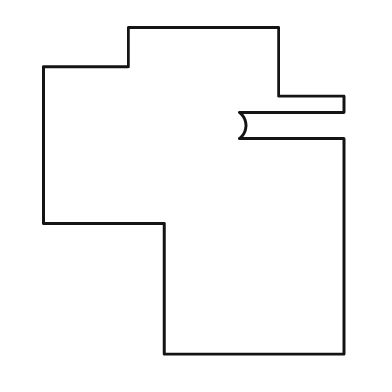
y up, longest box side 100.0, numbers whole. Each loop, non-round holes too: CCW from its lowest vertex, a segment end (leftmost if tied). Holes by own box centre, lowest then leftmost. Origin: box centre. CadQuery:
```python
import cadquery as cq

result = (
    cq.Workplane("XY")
    .moveTo(-9.0, -50.0)
    .lineTo(46.0, -50.0)
    .lineTo(46.0, 16.0)
    .lineTo(14.0, 16.0)
    .threePointArc((16.0, 20.0), (14.0, 24.0))
    .lineTo(46.0, 24.0)
    .lineTo(46.0, 29.0)
    .lineTo(26.0, 29.0)
    .lineTo(26.0, 50.0)
    .lineTo(-20.0, 50.0)
    .lineTo(-20.0, 38.0)
    .lineTo(-46.0, 38.0)
    .lineTo(-46.0, -10.0)
    .lineTo(-9.0, -10.0)
    .close()
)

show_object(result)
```